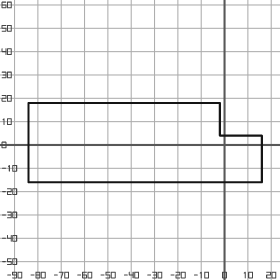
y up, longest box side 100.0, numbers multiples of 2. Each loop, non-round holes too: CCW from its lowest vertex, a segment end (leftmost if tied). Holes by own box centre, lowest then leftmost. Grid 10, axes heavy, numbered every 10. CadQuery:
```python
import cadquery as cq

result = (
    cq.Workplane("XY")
    .moveTo(-84.0, -16.0)
    .lineTo(16.0, -16.0)
    .lineTo(16.0, 4.0)
    .lineTo(-2.0, 4.0)
    .lineTo(-2.0, 18.0)
    .lineTo(-84.0, 18.0)
    .close()
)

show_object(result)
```